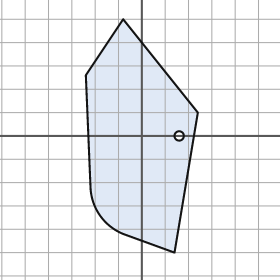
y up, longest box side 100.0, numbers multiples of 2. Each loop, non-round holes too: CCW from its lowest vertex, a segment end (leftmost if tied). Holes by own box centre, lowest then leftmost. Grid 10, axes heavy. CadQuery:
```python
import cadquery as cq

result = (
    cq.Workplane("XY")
    .moveTo(14.0, -50.0)
    .lineTo(24.0, 10.0)
    .lineTo(-8.0, 50.0)
    .lineTo(-24.0, 26.0)
    .lineTo(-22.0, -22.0)
    .threePointArc((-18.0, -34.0), (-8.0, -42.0))
    .close()
    .moveTo(16.0, 0.0)
    .circle(2.0)
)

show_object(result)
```